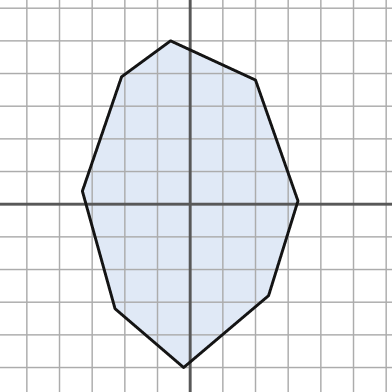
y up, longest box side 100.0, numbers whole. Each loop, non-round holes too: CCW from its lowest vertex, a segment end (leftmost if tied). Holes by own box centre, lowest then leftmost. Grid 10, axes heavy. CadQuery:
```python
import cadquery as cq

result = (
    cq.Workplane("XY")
    .moveTo(-2.0, -50.0)
    .lineTo(24.0, -28.0)
    .lineTo(33.0, 1.0)
    .lineTo(20.0, 38.0)
    .lineTo(-6.0, 50.0)
    .lineTo(-21.0, 39.0)
    .lineTo(-33.0, 4.0)
    .lineTo(-23.0, -32.0)
    .close()
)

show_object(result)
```